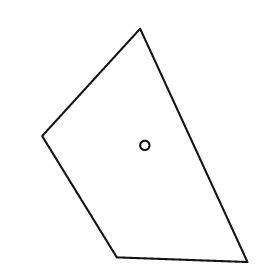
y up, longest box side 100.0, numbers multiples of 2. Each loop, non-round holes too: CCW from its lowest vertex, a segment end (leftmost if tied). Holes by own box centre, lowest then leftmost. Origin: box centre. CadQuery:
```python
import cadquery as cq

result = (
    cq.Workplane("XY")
    .moveTo(44.0, -50.0)
    .lineTo(-2.0, 50.0)
    .lineTo(-44.0, 4.0)
    .lineTo(-12.0, -48.0)
    .close()
    .moveTo(0.0, 0.0)
    .circle(2.0)
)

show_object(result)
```